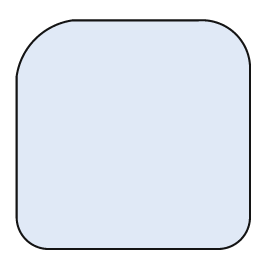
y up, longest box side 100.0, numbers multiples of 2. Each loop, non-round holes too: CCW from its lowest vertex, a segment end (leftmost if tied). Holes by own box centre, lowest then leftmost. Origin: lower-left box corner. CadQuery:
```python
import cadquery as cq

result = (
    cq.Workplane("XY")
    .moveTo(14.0, 0.0)
    .lineTo(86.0, 0.0)
    .threePointArc((96.0, 4.0), (100.0, 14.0))
    .lineTo(100.0, 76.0)
    .threePointArc((94.0, 92.0), (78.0, 98.0))
    .lineTo(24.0, 98.0)
    .threePointArc((8.0, 90.0), (0.0, 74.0))
    .lineTo(0.0, 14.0)
    .threePointArc((4.0, 4.0), (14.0, 0.0))
    .close()
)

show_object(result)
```